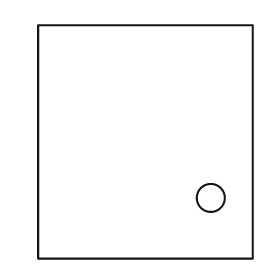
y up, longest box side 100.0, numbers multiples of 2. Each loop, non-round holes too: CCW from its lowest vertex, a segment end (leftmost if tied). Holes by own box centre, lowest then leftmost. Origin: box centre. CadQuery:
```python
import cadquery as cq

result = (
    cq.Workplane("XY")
    .moveTo(-46.0, -50.0)
    .lineTo(46.0, -50.0)
    .lineTo(46.0, 50.0)
    .lineTo(-46.0, 50.0)
    .close()
    .moveTo(28.0, -24.0)
    .circle(6.0)
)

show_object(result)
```